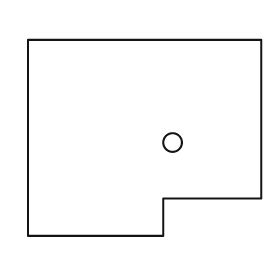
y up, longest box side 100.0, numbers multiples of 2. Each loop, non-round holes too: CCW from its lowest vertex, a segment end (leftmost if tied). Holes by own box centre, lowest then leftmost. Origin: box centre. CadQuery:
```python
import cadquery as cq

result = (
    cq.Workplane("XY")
    .moveTo(-50.0, -42.0)
    .lineTo(8.0, -42.0)
    .lineTo(8.0, -26.0)
    .lineTo(50.0, -26.0)
    .lineTo(50.0, 42.0)
    .lineTo(-50.0, 42.0)
    .close()
    .moveTo(12.0, -2.0)
    .circle(4.0)
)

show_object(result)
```